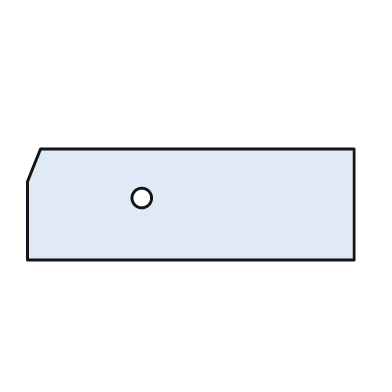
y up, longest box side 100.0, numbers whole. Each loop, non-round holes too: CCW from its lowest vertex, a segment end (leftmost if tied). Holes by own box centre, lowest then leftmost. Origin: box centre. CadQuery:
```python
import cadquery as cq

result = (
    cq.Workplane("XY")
    .moveTo(-50.0, -17.0)
    .lineTo(50.0, -17.0)
    .lineTo(50.0, 17.0)
    .lineTo(-46.0, 17.0)
    .lineTo(-50.0, 7.0)
    .close()
    .moveTo(-15.0, 2.0)
    .circle(3.0)
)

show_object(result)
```